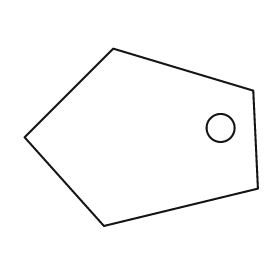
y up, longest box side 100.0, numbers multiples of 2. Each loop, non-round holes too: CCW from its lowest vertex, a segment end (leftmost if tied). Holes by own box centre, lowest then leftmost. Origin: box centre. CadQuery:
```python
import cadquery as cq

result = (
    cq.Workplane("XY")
    .moveTo(-16.0, -38.0)
    .lineTo(50.0, -22.0)
    .lineTo(48.0, 20.0)
    .lineTo(-12.0, 38.0)
    .lineTo(-50.0, 0.0)
    .close()
    .moveTo(34.0, 4.0)
    .circle(6.0)
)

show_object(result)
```